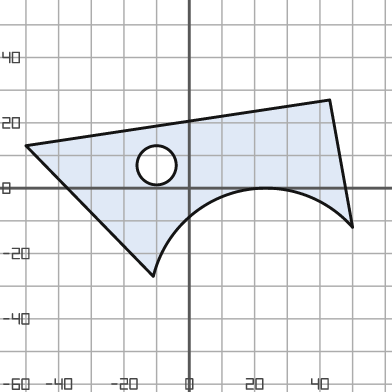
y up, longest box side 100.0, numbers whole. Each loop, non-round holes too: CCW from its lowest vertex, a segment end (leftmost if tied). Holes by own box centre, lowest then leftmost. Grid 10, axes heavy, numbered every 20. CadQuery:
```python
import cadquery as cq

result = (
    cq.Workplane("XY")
    .moveTo(-11.0, -27.0)
    .threePointArc((15.0, -1.0), (50.0, -12.0))
    .lineTo(43.0, 27.0)
    .lineTo(-50.0, 13.0)
    .close()
    .moveTo(-10.0, 7.0)
    .circle(6.0)
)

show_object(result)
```